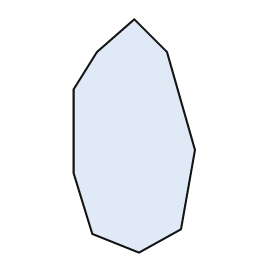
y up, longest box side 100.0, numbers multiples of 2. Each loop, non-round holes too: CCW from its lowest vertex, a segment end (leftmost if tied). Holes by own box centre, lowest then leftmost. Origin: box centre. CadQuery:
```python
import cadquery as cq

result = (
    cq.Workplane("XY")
    .moveTo(2.0, -50.0)
    .lineTo(20.0, -40.0)
    .lineTo(26.0, -6.0)
    .lineTo(14.0, 36.0)
    .lineTo(0.0, 50.0)
    .lineTo(-16.0, 36.0)
    .lineTo(-26.0, 20.0)
    .lineTo(-26.0, -16.0)
    .lineTo(-18.0, -42.0)
    .close()
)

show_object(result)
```